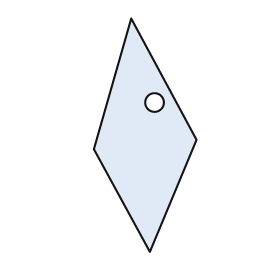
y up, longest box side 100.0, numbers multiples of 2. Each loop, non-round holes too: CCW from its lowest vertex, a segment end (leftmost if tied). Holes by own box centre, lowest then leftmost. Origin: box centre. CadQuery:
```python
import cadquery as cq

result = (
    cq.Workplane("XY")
    .moveTo(2.0, -50.0)
    .lineTo(22.0, -2.0)
    .lineTo(-6.0, 50.0)
    .lineTo(-22.0, -6.0)
    .close()
    .moveTo(4.0, 14.0)
    .circle(4.0)
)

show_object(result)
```